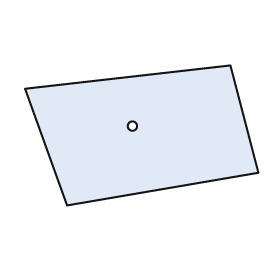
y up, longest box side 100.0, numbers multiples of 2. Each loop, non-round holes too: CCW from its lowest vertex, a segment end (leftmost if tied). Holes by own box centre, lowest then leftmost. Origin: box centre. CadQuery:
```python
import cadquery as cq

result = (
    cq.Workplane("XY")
    .moveTo(-32.0, -30.0)
    .lineTo(50.0, -16.0)
    .lineTo(38.0, 30.0)
    .lineTo(-50.0, 20.0)
    .close()
    .moveTo(-4.0, 4.0)
    .circle(2.0)
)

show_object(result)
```